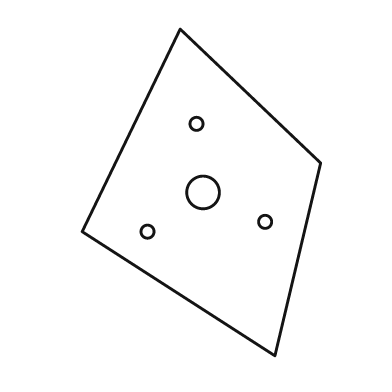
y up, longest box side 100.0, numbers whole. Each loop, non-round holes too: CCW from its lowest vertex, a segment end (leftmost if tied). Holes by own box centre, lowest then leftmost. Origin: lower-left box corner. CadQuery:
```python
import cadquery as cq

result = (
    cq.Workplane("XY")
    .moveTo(59.0, 0.0)
    .lineTo(73.0, 59.0)
    .lineTo(30.0, 100.0)
    .lineTo(0.0, 38.0)
    .close()
    .moveTo(20.0, 38.0)
    .circle(2.0)
    .moveTo(56.0, 41.0)
    .circle(2.0)
    .moveTo(37.0, 50.0)
    .circle(5.0)
    .moveTo(35.0, 71.0)
    .circle(2.0)
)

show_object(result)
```